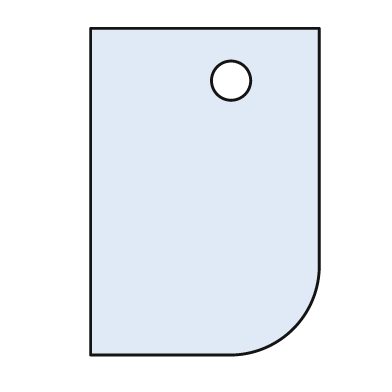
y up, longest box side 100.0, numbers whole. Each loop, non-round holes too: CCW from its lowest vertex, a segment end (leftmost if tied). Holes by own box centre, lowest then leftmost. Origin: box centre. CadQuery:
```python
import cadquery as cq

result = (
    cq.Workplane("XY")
    .moveTo(-35.0, -50.0)
    .lineTo(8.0, -50.0)
    .threePointArc((27.0, -42.0), (35.0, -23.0))
    .lineTo(35.0, 50.0)
    .lineTo(-35.0, 50.0)
    .close()
    .moveTo(8.0, 34.0)
    .circle(6.0)
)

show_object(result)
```